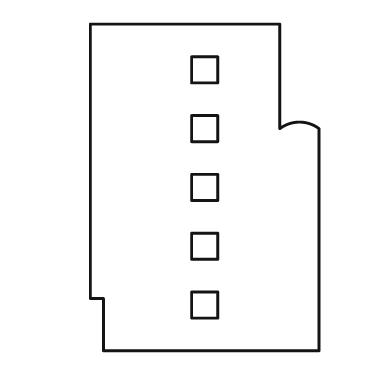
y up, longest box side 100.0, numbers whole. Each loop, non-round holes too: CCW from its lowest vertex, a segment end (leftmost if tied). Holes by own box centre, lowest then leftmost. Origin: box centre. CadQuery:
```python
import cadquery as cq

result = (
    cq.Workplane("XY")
    .moveTo(-31.0, -50.0)
    .lineTo(35.0, -50.0)
    .lineTo(35.0, 18.0)
    .threePointArc((29.0, 20.0), (23.0, 18.0))
    .lineTo(23.0, 50.0)
    .lineTo(-35.0, 50.0)
    .lineTo(-35.0, -34.0)
    .lineTo(-31.0, -34.0)
    .close()
    .moveTo(-4.0, -40.0)
    .lineTo(4.0, -40.0)
    .lineTo(4.0, -32.0)
    .lineTo(-4.0, -32.0)
    .close()
    .moveTo(-4.0, -22.0)
    .lineTo(4.0, -22.0)
    .lineTo(4.0, -14.0)
    .lineTo(-4.0, -14.0)
    .close()
    .moveTo(-4.0, -4.0)
    .lineTo(4.0, -4.0)
    .lineTo(4.0, 4.0)
    .lineTo(-4.0, 4.0)
    .close()
    .moveTo(-4.0, 14.0)
    .lineTo(4.0, 14.0)
    .lineTo(4.0, 22.0)
    .lineTo(-4.0, 22.0)
    .close()
    .moveTo(-4.0, 32.0)
    .lineTo(4.0, 32.0)
    .lineTo(4.0, 40.0)
    .lineTo(-4.0, 40.0)
    .close()
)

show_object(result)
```